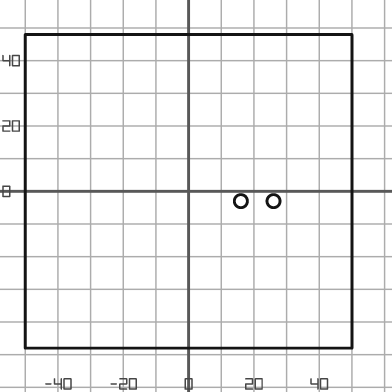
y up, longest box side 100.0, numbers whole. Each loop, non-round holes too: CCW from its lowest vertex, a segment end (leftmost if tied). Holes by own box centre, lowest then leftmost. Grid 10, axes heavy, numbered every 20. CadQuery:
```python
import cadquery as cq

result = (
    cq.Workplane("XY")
    .moveTo(-50.0, -48.0)
    .lineTo(50.0, -48.0)
    .lineTo(50.0, 48.0)
    .lineTo(-50.0, 48.0)
    .close()
    .moveTo(16.0, -3.0)
    .circle(2.0)
    .moveTo(26.0, -3.0)
    .circle(2.0)
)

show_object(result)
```